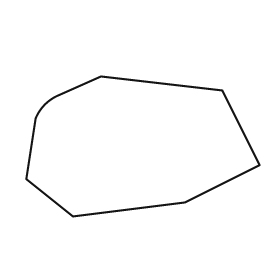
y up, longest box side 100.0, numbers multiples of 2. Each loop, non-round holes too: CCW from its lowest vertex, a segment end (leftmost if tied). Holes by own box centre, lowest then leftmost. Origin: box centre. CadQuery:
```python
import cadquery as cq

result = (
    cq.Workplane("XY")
    .moveTo(-30.0, -30.0)
    .lineTo(18.0, -24.0)
    .lineTo(50.0, -8.0)
    .lineTo(34.0, 24.0)
    .lineTo(-18.0, 30.0)
    .lineTo(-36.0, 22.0)
    .threePointArc((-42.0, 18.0), (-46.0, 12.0))
    .lineTo(-50.0, -14.0)
    .close()
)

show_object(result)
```